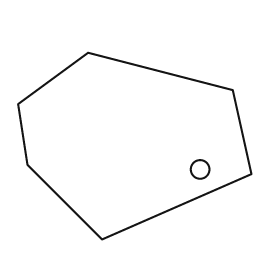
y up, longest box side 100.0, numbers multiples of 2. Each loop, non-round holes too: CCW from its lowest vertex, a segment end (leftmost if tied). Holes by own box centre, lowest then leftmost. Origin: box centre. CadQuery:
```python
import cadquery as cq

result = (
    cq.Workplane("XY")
    .moveTo(-14.0, -40.0)
    .lineTo(50.0, -12.0)
    .lineTo(42.0, 24.0)
    .lineTo(-20.0, 40.0)
    .lineTo(-50.0, 18.0)
    .lineTo(-46.0, -8.0)
    .close()
    .moveTo(28.0, -10.0)
    .circle(4.0)
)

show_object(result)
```